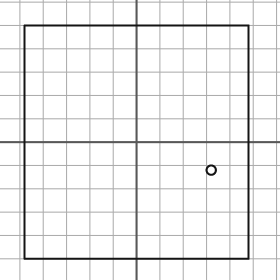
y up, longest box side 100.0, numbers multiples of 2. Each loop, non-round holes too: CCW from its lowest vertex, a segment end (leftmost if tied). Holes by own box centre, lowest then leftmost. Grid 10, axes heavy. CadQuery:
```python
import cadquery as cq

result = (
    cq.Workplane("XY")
    .moveTo(-48.0, -50.0)
    .lineTo(48.0, -50.0)
    .lineTo(48.0, 50.0)
    .lineTo(-48.0, 50.0)
    .close()
    .moveTo(32.0, -12.0)
    .circle(2.0)
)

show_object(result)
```